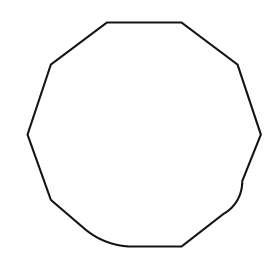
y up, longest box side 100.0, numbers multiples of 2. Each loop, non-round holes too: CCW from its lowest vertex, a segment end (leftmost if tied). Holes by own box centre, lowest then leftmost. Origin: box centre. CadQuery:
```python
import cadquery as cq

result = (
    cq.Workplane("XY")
    .moveTo(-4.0, -48.0)
    .lineTo(16.0, -48.0)
    .lineTo(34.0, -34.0)
    .threePointArc((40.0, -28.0), (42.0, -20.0))
    .lineTo(50.0, 0.0)
    .lineTo(40.0, 30.0)
    .lineTo(16.0, 48.0)
    .lineTo(-16.0, 48.0)
    .lineTo(-40.0, 30.0)
    .lineTo(-50.0, 0.0)
    .lineTo(-40.0, -28.0)
    .lineTo(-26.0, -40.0)
    .threePointArc((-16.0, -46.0), (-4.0, -48.0))
    .close()
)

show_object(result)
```